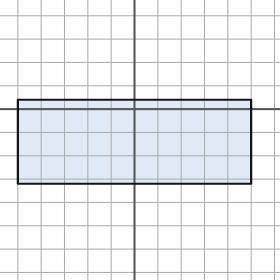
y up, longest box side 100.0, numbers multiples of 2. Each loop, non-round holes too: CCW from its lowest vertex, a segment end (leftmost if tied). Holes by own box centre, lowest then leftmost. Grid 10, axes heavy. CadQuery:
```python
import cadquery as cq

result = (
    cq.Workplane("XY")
    .moveTo(-50.0, -32.0)
    .lineTo(50.0, -32.0)
    .lineTo(50.0, 4.0)
    .lineTo(-50.0, 4.0)
    .close()
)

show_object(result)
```